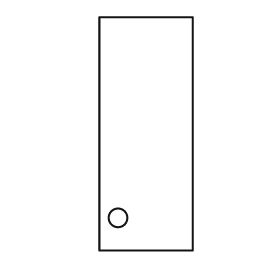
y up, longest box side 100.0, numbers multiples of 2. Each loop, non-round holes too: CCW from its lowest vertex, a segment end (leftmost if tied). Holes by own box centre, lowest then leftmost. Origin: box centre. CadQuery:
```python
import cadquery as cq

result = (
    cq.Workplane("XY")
    .moveTo(-20.0, -50.0)
    .lineTo(20.0, -50.0)
    .lineTo(20.0, 50.0)
    .lineTo(-20.0, 50.0)
    .close()
    .moveTo(-12.0, -36.0)
    .circle(4.0)
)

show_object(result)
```